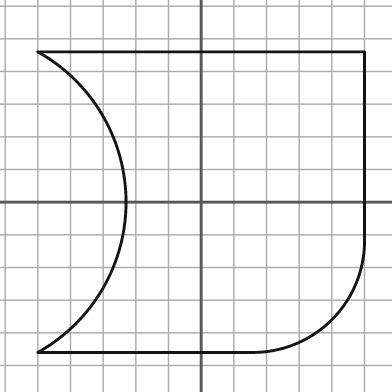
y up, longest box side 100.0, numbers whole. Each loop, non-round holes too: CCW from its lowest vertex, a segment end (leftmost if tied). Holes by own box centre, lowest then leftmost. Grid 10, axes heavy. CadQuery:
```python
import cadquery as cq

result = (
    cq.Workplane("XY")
    .moveTo(-50.0, -46.0)
    .lineTo(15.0, -46.0)
    .threePointArc((40.0, -36.0), (50.0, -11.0))
    .lineTo(50.0, 46.0)
    .lineTo(-50.0, 46.0)
    .threePointArc((-23.0, 0.0), (-50.0, -46.0))
    .close()
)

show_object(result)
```